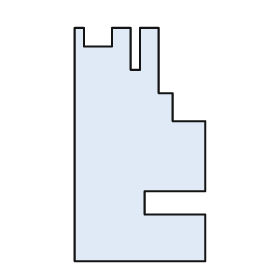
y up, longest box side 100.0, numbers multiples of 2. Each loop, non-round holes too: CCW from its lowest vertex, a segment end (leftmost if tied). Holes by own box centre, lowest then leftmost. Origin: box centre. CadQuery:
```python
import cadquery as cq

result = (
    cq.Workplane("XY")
    .moveTo(-28.0, -50.0)
    .lineTo(28.0, -50.0)
    .lineTo(28.0, -30.0)
    .lineTo(2.0, -30.0)
    .lineTo(2.0, -20.0)
    .lineTo(28.0, -20.0)
    .lineTo(28.0, 10.0)
    .lineTo(14.0, 10.0)
    .lineTo(14.0, 22.0)
    .lineTo(8.0, 22.0)
    .lineTo(8.0, 50.0)
    .lineTo(0.0, 50.0)
    .lineTo(0.0, 32.0)
    .lineTo(-4.0, 32.0)
    .lineTo(-4.0, 50.0)
    .lineTo(-12.0, 50.0)
    .lineTo(-12.0, 42.0)
    .lineTo(-24.0, 42.0)
    .lineTo(-24.0, 50.0)
    .lineTo(-28.0, 50.0)
    .close()
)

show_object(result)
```